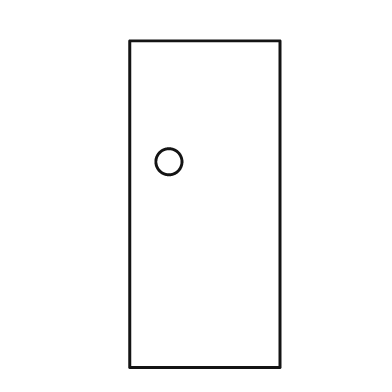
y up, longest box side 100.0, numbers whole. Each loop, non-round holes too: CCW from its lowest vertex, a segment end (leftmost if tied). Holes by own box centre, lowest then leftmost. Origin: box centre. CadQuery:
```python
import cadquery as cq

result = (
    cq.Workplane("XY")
    .moveTo(-23.0, -50.0)
    .lineTo(23.0, -50.0)
    .lineTo(23.0, 50.0)
    .lineTo(-23.0, 50.0)
    .close()
    .moveTo(-11.0, 13.0)
    .circle(4.0)
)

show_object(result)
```